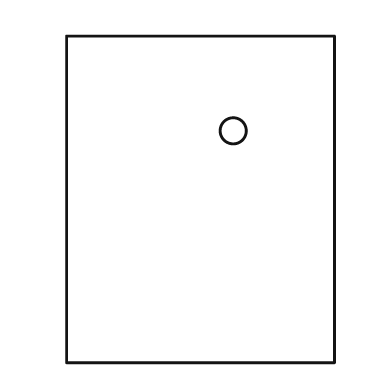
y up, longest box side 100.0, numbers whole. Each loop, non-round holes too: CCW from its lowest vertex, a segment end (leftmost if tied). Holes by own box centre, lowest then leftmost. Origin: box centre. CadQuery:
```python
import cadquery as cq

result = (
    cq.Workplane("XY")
    .moveTo(-41.0, -50.0)
    .lineTo(41.0, -50.0)
    .lineTo(41.0, 50.0)
    .lineTo(-41.0, 50.0)
    .close()
    .moveTo(10.0, 21.0)
    .circle(4.0)
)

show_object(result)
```